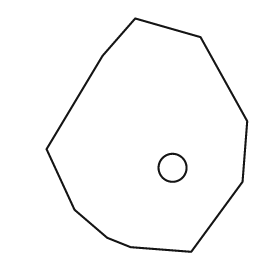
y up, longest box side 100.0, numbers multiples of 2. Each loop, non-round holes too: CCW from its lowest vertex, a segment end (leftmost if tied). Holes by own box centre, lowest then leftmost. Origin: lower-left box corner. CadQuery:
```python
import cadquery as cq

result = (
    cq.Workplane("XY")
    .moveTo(62.0, 0.0)
    .lineTo(84.0, 30.0)
    .lineTo(86.0, 56.0)
    .lineTo(66.0, 92.0)
    .lineTo(38.0, 100.0)
    .lineTo(24.0, 84.0)
    .lineTo(0.0, 44.0)
    .lineTo(12.0, 18.0)
    .lineTo(26.0, 6.0)
    .lineTo(36.0, 2.0)
    .close()
    .moveTo(54.0, 36.0)
    .circle(6.0)
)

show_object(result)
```